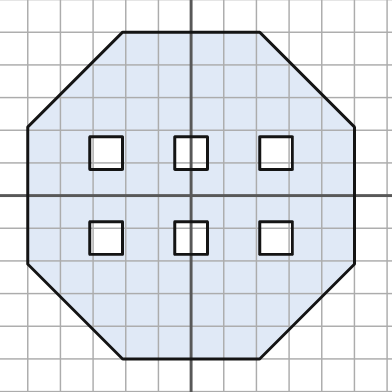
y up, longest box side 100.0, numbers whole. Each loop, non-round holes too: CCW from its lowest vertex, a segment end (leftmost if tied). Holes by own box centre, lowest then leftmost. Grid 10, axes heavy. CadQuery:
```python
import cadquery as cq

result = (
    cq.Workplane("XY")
    .moveTo(-21.0, -50.0)
    .lineTo(21.0, -50.0)
    .lineTo(50.0, -21.0)
    .lineTo(50.0, 21.0)
    .lineTo(21.0, 50.0)
    .lineTo(-21.0, 50.0)
    .lineTo(-50.0, 21.0)
    .lineTo(-50.0, -21.0)
    .close()
    .moveTo(-31.0, -18.0)
    .lineTo(-21.0, -18.0)
    .lineTo(-21.0, -8.0)
    .lineTo(-31.0, -8.0)
    .close()
    .moveTo(-5.0, -18.0)
    .lineTo(5.0, -18.0)
    .lineTo(5.0, -8.0)
    .lineTo(-5.0, -8.0)
    .close()
    .moveTo(21.0, -18.0)
    .lineTo(31.0, -18.0)
    .lineTo(31.0, -8.0)
    .lineTo(21.0, -8.0)
    .close()
    .moveTo(-31.0, 8.0)
    .lineTo(-21.0, 8.0)
    .lineTo(-21.0, 18.0)
    .lineTo(-31.0, 18.0)
    .close()
    .moveTo(-5.0, 8.0)
    .lineTo(5.0, 8.0)
    .lineTo(5.0, 18.0)
    .lineTo(-5.0, 18.0)
    .close()
    .moveTo(21.0, 8.0)
    .lineTo(31.0, 8.0)
    .lineTo(31.0, 18.0)
    .lineTo(21.0, 18.0)
    .close()
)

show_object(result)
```